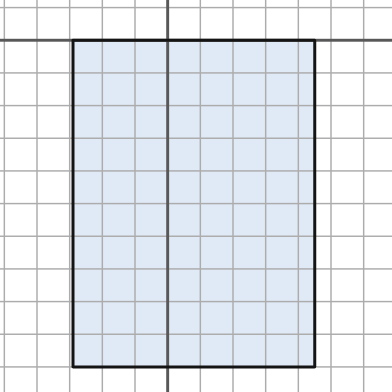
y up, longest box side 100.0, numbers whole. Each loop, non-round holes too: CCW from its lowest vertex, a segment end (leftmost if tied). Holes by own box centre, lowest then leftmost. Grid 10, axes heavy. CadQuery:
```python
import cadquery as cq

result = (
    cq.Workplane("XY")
    .moveTo(-29.0, -100.0)
    .lineTo(45.0, -100.0)
    .lineTo(45.0, 0.0)
    .lineTo(-29.0, 0.0)
    .close()
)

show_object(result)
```